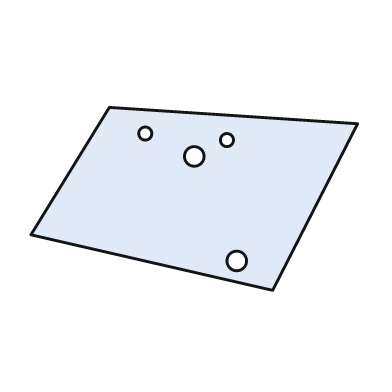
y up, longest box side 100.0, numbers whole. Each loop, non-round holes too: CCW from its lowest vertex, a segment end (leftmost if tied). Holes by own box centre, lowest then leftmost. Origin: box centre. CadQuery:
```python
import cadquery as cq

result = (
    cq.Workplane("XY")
    .moveTo(24.0, -28.0)
    .lineTo(50.0, 23.0)
    .lineTo(-26.0, 28.0)
    .lineTo(-50.0, -11.0)
    .close()
    .moveTo(13.0, -19.0)
    .circle(3.0)
    .moveTo(0.0, 13.0)
    .circle(3.0)
    .moveTo(10.0, 18.0)
    .circle(2.0)
    .moveTo(-15.0, 20.0)
    .circle(2.0)
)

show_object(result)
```